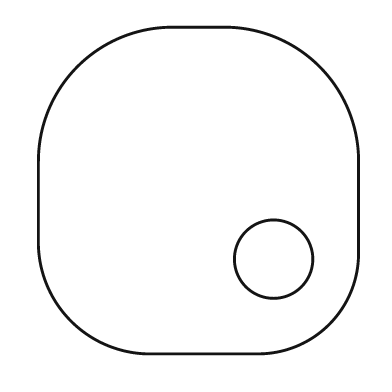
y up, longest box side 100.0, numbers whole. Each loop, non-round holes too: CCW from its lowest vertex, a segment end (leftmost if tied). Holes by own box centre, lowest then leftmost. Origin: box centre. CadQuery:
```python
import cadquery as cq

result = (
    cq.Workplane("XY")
    .moveTo(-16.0, -50.0)
    .lineTo(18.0, -50.0)
    .threePointArc((40.0, -41.0), (49.0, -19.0))
    .lineTo(49.0, 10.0)
    .threePointArc((37.0, 38.0), (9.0, 50.0))
    .lineTo(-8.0, 50.0)
    .threePointArc((-37.0, 38.0), (-49.0, 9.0))
    .lineTo(-49.0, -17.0)
    .threePointArc((-39.0, -40.0), (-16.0, -50.0))
    .close()
    .moveTo(23.0, -21.0)
    .circle(12.0)
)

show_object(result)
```